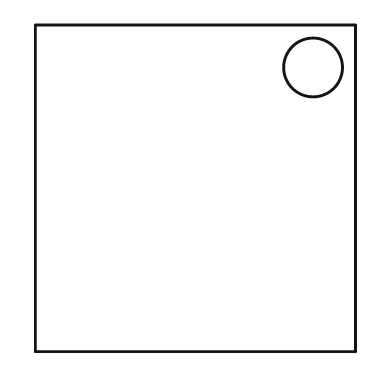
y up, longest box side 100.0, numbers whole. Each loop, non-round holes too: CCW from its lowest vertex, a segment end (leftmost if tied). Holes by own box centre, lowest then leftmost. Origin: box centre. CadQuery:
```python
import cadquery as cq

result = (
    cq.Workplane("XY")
    .moveTo(-49.0, -50.0)
    .lineTo(49.0, -50.0)
    .lineTo(49.0, 50.0)
    .lineTo(-49.0, 50.0)
    .close()
    .moveTo(36.0, 37.0)
    .circle(9.0)
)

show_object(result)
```